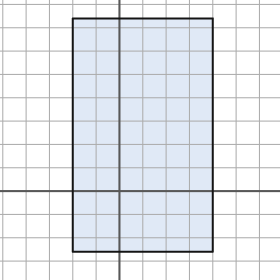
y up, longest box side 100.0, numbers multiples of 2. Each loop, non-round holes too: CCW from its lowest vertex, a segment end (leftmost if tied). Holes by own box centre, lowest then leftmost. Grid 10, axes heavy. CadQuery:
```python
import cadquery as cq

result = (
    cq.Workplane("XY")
    .moveTo(-20.0, -26.0)
    .lineTo(40.0, -26.0)
    .lineTo(40.0, 74.0)
    .lineTo(-20.0, 74.0)
    .close()
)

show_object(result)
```